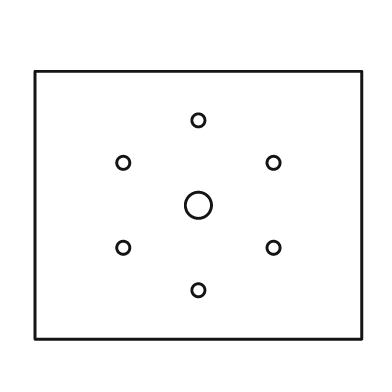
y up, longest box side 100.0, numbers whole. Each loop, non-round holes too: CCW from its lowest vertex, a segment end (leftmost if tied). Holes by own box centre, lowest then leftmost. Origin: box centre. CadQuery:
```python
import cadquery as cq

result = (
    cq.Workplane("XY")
    .moveTo(-50.0, -41.0)
    .lineTo(50.0, -41.0)
    .lineTo(50.0, 41.0)
    .lineTo(-50.0, 41.0)
    .close()
    .moveTo(0.0, -26.0)
    .circle(2.0)
    .moveTo(-23.0, -13.0)
    .circle(2.0)
    .moveTo(23.0, -13.0)
    .circle(2.0)
    .moveTo(0.0, 0.0)
    .circle(4.0)
    .moveTo(-23.0, 13.0)
    .circle(2.0)
    .moveTo(23.0, 13.0)
    .circle(2.0)
    .moveTo(0.0, 26.0)
    .circle(2.0)
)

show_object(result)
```